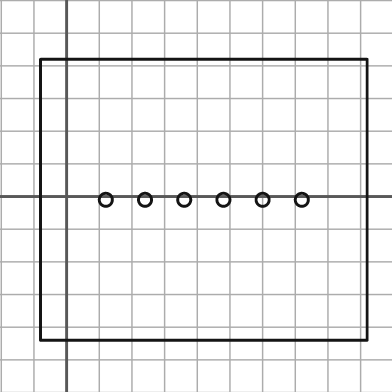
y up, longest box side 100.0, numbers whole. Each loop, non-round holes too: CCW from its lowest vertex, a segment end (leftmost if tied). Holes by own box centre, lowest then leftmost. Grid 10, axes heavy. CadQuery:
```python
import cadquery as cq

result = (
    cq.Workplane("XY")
    .moveTo(-8.0, -44.0)
    .lineTo(92.0, -44.0)
    .lineTo(92.0, 42.0)
    .lineTo(-8.0, 42.0)
    .close()
    .moveTo(12.0, -1.0)
    .circle(2.0)
    .moveTo(24.0, -1.0)
    .circle(2.0)
    .moveTo(36.0, -1.0)
    .circle(2.0)
    .moveTo(48.0, -1.0)
    .circle(2.0)
    .moveTo(60.0, -1.0)
    .circle(2.0)
    .moveTo(72.0, -1.0)
    .circle(2.0)
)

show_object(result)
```